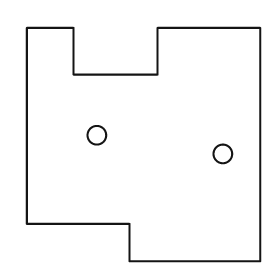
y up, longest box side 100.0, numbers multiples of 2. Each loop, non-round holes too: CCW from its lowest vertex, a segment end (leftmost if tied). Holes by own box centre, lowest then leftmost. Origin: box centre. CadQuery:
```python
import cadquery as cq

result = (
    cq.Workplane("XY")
    .moveTo(-6.0, -50.0)
    .lineTo(50.0, -50.0)
    .lineTo(50.0, 50.0)
    .lineTo(6.0, 50.0)
    .lineTo(6.0, 30.0)
    .lineTo(-30.0, 30.0)
    .lineTo(-30.0, 50.0)
    .lineTo(-50.0, 50.0)
    .lineTo(-50.0, -34.0)
    .lineTo(-6.0, -34.0)
    .close()
    .moveTo(34.0, -4.0)
    .circle(4.0)
    .moveTo(-20.0, 4.0)
    .circle(4.0)
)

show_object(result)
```